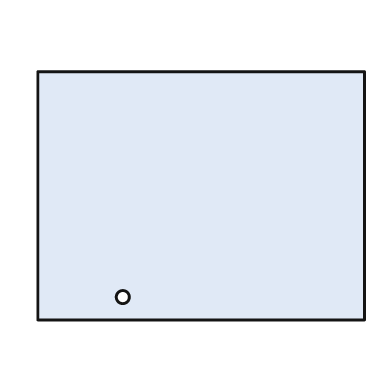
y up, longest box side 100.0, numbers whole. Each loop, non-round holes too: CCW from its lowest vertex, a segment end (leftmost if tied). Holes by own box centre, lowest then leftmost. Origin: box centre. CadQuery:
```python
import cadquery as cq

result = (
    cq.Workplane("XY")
    .moveTo(-50.0, -38.0)
    .lineTo(50.0, -38.0)
    .lineTo(50.0, 38.0)
    .lineTo(-50.0, 38.0)
    .close()
    .moveTo(-24.0, -31.0)
    .circle(2.0)
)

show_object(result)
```